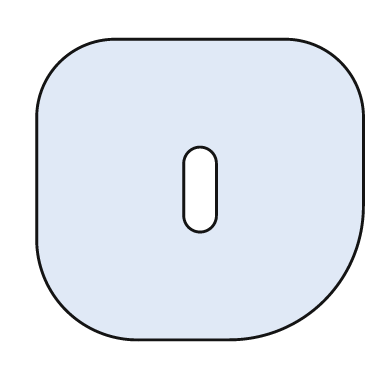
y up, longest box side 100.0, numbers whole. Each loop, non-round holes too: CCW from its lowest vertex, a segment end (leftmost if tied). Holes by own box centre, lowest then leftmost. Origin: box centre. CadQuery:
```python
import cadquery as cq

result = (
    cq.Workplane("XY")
    .moveTo(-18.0, -46.0)
    .lineTo(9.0, -46.0)
    .threePointArc((38.0, -34.0), (50.0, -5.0))
    .lineTo(50.0, 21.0)
    .threePointArc((43.0, 39.0), (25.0, 46.0))
    .lineTo(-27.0, 46.0)
    .threePointArc((-43.0, 39.0), (-50.0, 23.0))
    .lineTo(-50.0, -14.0)
    .threePointArc((-41.0, -37.0), (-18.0, -46.0))
    .close()
    .moveTo(-5.0, -8.0)
    .threePointArc((0.0, -13.0), (5.0, -8.0))
    .lineTo(5.0, 8.0)
    .threePointArc((0.0, 13.0), (-5.0, 8.0))
    .close()
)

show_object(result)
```